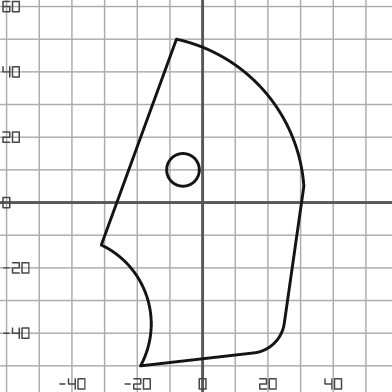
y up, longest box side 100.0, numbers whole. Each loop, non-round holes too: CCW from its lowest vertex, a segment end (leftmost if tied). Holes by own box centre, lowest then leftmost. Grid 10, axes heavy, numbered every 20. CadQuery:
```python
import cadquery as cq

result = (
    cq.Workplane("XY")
    .moveTo(-19.0, -50.0)
    .lineTo(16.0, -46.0)
    .threePointArc((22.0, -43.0), (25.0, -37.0))
    .lineTo(31.0, 5.0)
    .threePointArc((19.0, 34.0), (-8.0, 50.0))
    .lineTo(-31.0, -13.0)
    .threePointArc((-17.0, -29.0), (-19.0, -50.0))
    .close()
    .moveTo(-6.0, 10.0)
    .circle(5.0)
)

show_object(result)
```